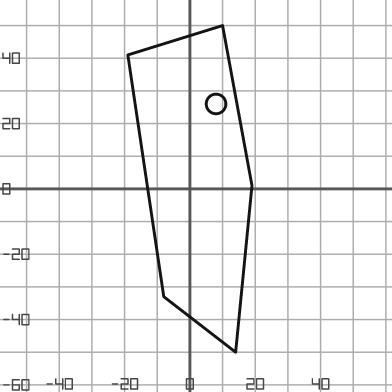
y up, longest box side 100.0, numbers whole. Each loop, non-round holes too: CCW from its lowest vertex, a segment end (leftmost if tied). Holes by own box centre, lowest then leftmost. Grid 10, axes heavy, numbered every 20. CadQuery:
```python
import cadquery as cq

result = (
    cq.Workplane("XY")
    .moveTo(14.0, -50.0)
    .lineTo(19.0, 1.0)
    .lineTo(10.0, 50.0)
    .lineTo(-19.0, 41.0)
    .lineTo(-8.0, -33.0)
    .close()
    .moveTo(8.0, 26.0)
    .circle(3.0)
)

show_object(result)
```